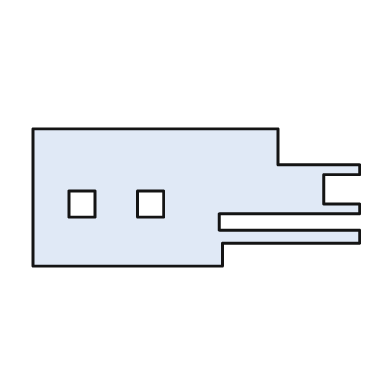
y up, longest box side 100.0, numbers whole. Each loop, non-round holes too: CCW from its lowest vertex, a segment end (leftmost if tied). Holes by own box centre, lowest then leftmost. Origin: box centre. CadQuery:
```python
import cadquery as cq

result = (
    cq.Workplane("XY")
    .moveTo(-50.0, -21.0)
    .lineTo(8.0, -21.0)
    .lineTo(8.0, -14.0)
    .lineTo(50.0, -14.0)
    .lineTo(50.0, -10.0)
    .lineTo(7.0, -10.0)
    .lineTo(7.0, -5.0)
    .lineTo(50.0, -5.0)
    .lineTo(50.0, -2.0)
    .lineTo(39.0, -2.0)
    .lineTo(39.0, 7.0)
    .lineTo(50.0, 7.0)
    .lineTo(50.0, 10.0)
    .lineTo(25.0, 10.0)
    .lineTo(25.0, 21.0)
    .lineTo(-50.0, 21.0)
    .close()
    .moveTo(-39.0, -6.0)
    .lineTo(-31.0, -6.0)
    .lineTo(-31.0, 2.0)
    .lineTo(-39.0, 2.0)
    .close()
    .moveTo(-18.0, -6.0)
    .lineTo(-10.0, -6.0)
    .lineTo(-10.0, 2.0)
    .lineTo(-18.0, 2.0)
    .close()
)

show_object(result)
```